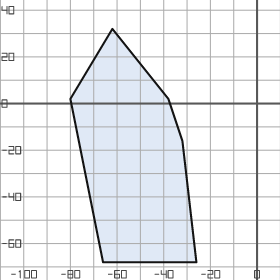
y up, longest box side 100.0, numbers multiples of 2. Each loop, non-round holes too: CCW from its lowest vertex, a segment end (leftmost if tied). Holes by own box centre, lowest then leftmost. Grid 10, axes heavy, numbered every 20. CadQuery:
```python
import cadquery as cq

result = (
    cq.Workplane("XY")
    .moveTo(-66.0, -68.0)
    .lineTo(-26.0, -68.0)
    .lineTo(-32.0, -16.0)
    .lineTo(-38.0, 2.0)
    .lineTo(-62.0, 32.0)
    .lineTo(-80.0, 2.0)
    .close()
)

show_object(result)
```